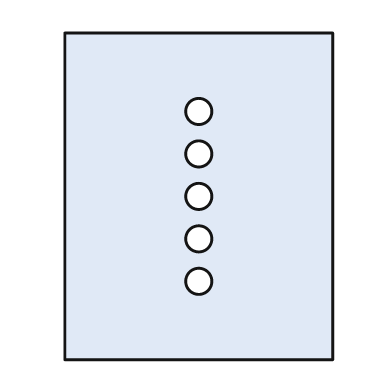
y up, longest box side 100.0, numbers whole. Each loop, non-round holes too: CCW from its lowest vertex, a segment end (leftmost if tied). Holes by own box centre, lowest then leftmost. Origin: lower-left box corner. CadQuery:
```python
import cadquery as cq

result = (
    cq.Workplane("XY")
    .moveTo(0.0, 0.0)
    .lineTo(82.0, 0.0)
    .lineTo(82.0, 100.0)
    .lineTo(0.0, 100.0)
    .close()
    .moveTo(41.0, 24.0)
    .circle(4.0)
    .moveTo(41.0, 37.0)
    .circle(4.0)
    .moveTo(41.0, 50.0)
    .circle(4.0)
    .moveTo(41.0, 63.0)
    .circle(4.0)
    .moveTo(41.0, 76.0)
    .circle(4.0)
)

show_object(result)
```